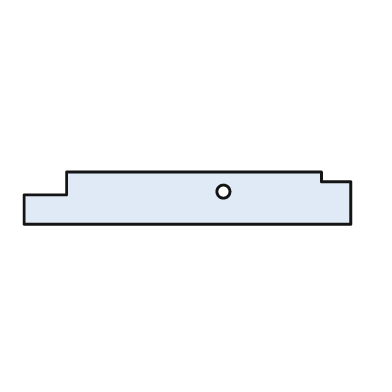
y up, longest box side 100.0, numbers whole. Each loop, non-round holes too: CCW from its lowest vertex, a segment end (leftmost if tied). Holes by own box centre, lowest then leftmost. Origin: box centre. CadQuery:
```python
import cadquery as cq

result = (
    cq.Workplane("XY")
    .moveTo(-50.0, -8.0)
    .lineTo(50.0, -8.0)
    .lineTo(50.0, 5.0)
    .lineTo(41.0, 5.0)
    .lineTo(41.0, 8.0)
    .lineTo(-37.0, 8.0)
    .lineTo(-37.0, 1.0)
    .lineTo(-50.0, 1.0)
    .close()
    .moveTo(11.0, 2.0)
    .circle(2.0)
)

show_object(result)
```